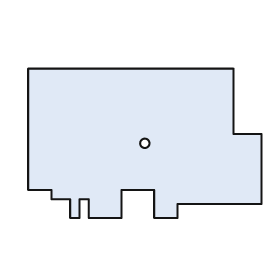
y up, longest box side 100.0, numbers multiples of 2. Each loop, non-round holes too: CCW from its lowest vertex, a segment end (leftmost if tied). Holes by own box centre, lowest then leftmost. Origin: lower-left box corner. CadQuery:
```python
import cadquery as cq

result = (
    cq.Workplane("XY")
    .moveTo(18.0, 0.0)
    .lineTo(22.0, 0.0)
    .lineTo(22.0, 8.0)
    .lineTo(26.0, 8.0)
    .lineTo(26.0, 0.0)
    .lineTo(40.0, 0.0)
    .lineTo(40.0, 12.0)
    .lineTo(54.0, 12.0)
    .lineTo(54.0, 0.0)
    .lineTo(64.0, 0.0)
    .lineTo(64.0, 6.0)
    .lineTo(100.0, 6.0)
    .lineTo(100.0, 36.0)
    .lineTo(88.0, 36.0)
    .lineTo(88.0, 64.0)
    .lineTo(0.0, 64.0)
    .lineTo(0.0, 12.0)
    .lineTo(10.0, 12.0)
    .lineTo(10.0, 8.0)
    .lineTo(18.0, 8.0)
    .close()
    .moveTo(50.0, 32.0)
    .circle(2.0)
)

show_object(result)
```